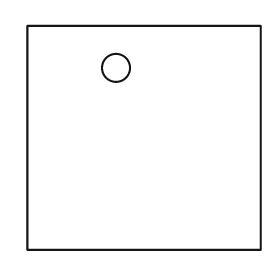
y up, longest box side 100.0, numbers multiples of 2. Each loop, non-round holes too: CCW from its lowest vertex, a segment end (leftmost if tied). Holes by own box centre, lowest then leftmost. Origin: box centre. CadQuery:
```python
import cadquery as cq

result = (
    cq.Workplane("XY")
    .moveTo(-50.0, -48.0)
    .lineTo(50.0, -48.0)
    .lineTo(50.0, 48.0)
    .lineTo(-50.0, 48.0)
    .close()
    .moveTo(-12.0, 30.0)
    .circle(6.0)
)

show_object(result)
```